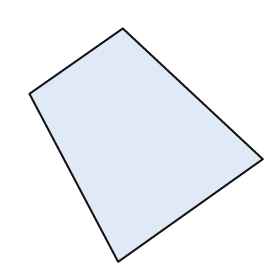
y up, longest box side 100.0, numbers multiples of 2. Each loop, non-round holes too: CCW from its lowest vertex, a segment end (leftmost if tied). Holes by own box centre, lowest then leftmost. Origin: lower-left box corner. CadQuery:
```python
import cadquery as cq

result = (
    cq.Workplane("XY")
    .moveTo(38.0, 0.0)
    .lineTo(100.0, 44.0)
    .lineTo(40.0, 100.0)
    .lineTo(0.0, 72.0)
    .close()
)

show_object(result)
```